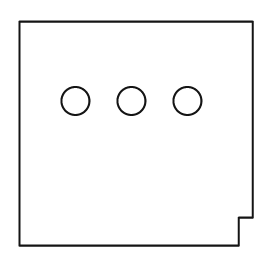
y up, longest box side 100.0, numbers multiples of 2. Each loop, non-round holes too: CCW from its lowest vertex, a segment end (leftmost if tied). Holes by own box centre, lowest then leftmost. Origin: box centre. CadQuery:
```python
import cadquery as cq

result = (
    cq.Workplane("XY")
    .moveTo(-50.0, -48.0)
    .lineTo(44.0, -48.0)
    .lineTo(44.0, -36.0)
    .lineTo(50.0, -36.0)
    .lineTo(50.0, 48.0)
    .lineTo(-50.0, 48.0)
    .close()
    .moveTo(-26.0, 14.0)
    .circle(6.0)
    .moveTo(-2.0, 14.0)
    .circle(6.0)
    .moveTo(22.0, 14.0)
    .circle(6.0)
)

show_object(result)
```